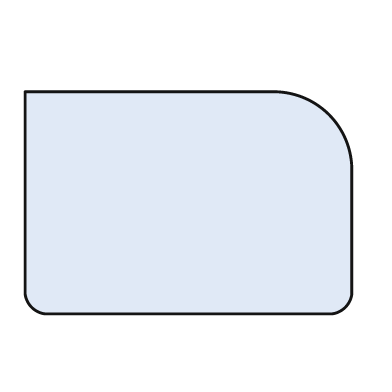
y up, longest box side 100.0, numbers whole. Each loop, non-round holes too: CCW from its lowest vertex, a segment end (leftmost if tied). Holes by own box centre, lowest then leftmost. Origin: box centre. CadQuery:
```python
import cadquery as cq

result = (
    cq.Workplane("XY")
    .moveTo(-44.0, -34.0)
    .lineTo(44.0, -34.0)
    .threePointArc((48.0, -32.0), (50.0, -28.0))
    .lineTo(50.0, 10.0)
    .threePointArc((43.0, 27.0), (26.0, 34.0))
    .lineTo(-50.0, 34.0)
    .lineTo(-50.0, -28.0)
    .threePointArc((-48.0, -32.0), (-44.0, -34.0))
    .close()
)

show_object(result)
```